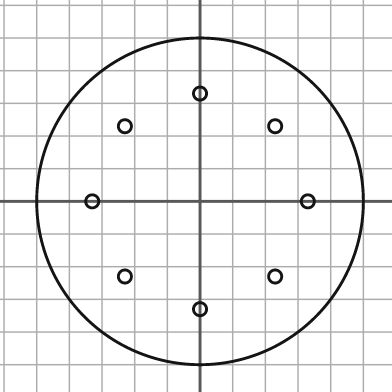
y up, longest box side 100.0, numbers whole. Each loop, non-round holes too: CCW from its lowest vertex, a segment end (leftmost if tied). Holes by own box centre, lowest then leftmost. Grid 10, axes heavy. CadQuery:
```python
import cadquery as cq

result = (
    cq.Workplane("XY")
    .moveTo(0.0, 0.0)
    .circle(50.0)
    .moveTo(0.0, -33.0)
    .circle(2.0)
    .moveTo(-23.0, -23.0)
    .circle(2.0)
    .moveTo(23.0, -23.0)
    .circle(2.0)
    .moveTo(-33.0, 0.0)
    .circle(2.0)
    .moveTo(33.0, 0.0)
    .circle(2.0)
    .moveTo(-23.0, 23.0)
    .circle(2.0)
    .moveTo(23.0, 23.0)
    .circle(2.0)
    .moveTo(0.0, 33.0)
    .circle(2.0)
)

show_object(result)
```